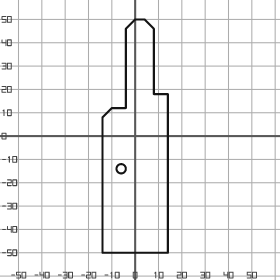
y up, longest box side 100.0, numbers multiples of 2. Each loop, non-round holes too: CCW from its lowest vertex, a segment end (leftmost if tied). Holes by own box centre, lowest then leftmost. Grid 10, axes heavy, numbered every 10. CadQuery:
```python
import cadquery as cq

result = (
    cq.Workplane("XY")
    .moveTo(-14.0, -50.0)
    .lineTo(14.0, -50.0)
    .lineTo(14.0, 18.0)
    .lineTo(8.0, 18.0)
    .lineTo(8.0, 46.0)
    .lineTo(4.0, 50.0)
    .lineTo(0.0, 50.0)
    .lineTo(-4.0, 46.0)
    .lineTo(-4.0, 12.0)
    .lineTo(-10.0, 12.0)
    .lineTo(-14.0, 8.0)
    .close()
    .moveTo(-6.0, -14.0)
    .circle(2.0)
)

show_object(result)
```